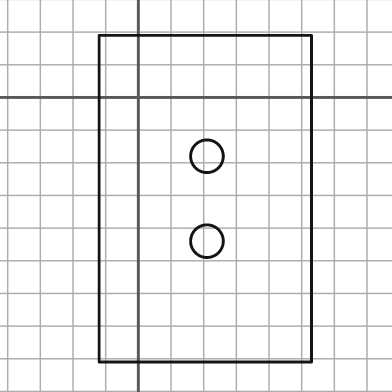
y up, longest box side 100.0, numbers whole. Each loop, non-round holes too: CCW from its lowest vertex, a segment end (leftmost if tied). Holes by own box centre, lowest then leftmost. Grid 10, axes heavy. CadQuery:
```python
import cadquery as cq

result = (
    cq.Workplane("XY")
    .moveTo(-12.0, -81.0)
    .lineTo(53.0, -81.0)
    .lineTo(53.0, 19.0)
    .lineTo(-12.0, 19.0)
    .close()
    .moveTo(21.0, -44.0)
    .circle(5.0)
    .moveTo(21.0, -18.0)
    .circle(5.0)
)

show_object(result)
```